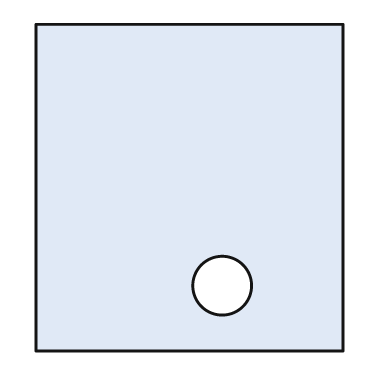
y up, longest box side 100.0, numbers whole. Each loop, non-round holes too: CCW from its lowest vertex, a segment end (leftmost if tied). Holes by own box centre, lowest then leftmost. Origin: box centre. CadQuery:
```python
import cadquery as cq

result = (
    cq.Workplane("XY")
    .moveTo(-47.0, -50.0)
    .lineTo(47.0, -50.0)
    .lineTo(47.0, 50.0)
    .lineTo(-47.0, 50.0)
    .close()
    .moveTo(10.0, -30.0)
    .circle(9.0)
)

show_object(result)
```